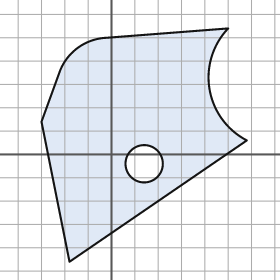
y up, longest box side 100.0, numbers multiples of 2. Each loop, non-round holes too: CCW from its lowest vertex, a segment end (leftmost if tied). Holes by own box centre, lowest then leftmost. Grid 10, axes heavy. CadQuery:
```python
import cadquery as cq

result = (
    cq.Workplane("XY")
    .moveTo(-18.0, -46.0)
    .lineTo(58.0, 6.0)
    .threePointArc((42.0, 28.0), (50.0, 54.0))
    .lineTo(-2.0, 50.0)
    .threePointArc((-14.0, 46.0), (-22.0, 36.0))
    .lineTo(-30.0, 14.0)
    .close()
    .moveTo(14.0, -4.0)
    .circle(8.0)
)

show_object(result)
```